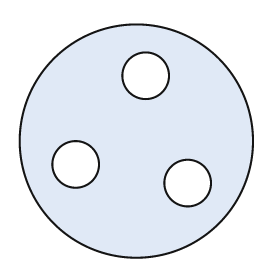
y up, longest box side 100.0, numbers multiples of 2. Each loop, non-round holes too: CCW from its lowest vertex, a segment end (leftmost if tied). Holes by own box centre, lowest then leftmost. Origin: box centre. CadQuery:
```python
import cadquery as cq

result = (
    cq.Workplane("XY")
    .moveTo(0.0, 0.0)
    .circle(50.0)
    .moveTo(22.0, -18.0)
    .circle(10.0)
    .moveTo(-26.0, -10.0)
    .circle(10.0)
    .moveTo(4.0, 28.0)
    .circle(10.0)
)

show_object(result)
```